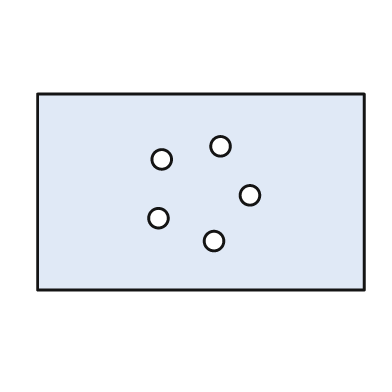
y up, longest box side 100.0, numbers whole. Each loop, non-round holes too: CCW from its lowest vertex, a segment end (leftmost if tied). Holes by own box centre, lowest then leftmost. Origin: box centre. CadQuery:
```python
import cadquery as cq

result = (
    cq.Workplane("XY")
    .moveTo(-50.0, -30.0)
    .lineTo(50.0, -30.0)
    .lineTo(50.0, 30.0)
    .lineTo(-50.0, 30.0)
    .close()
    .moveTo(4.0, -15.0)
    .circle(3.0)
    .moveTo(-13.0, -8.0)
    .circle(3.0)
    .moveTo(15.0, -1.0)
    .circle(3.0)
    .moveTo(-12.0, 10.0)
    .circle(3.0)
    .moveTo(6.0, 14.0)
    .circle(3.0)
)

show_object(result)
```